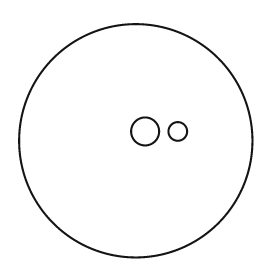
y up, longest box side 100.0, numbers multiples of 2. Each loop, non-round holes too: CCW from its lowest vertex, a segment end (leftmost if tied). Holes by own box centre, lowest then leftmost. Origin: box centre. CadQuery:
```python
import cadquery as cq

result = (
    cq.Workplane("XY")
    .moveTo(0.0, 0.0)
    .circle(50.0)
    .moveTo(4.0, 4.0)
    .circle(6.0)
    .moveTo(18.0, 4.0)
    .circle(4.0)
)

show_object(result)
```